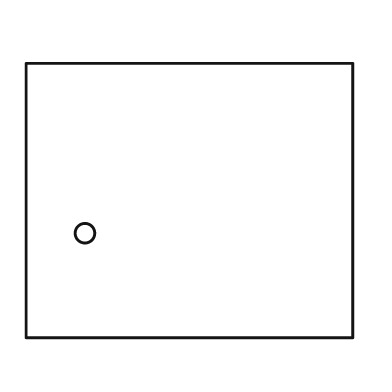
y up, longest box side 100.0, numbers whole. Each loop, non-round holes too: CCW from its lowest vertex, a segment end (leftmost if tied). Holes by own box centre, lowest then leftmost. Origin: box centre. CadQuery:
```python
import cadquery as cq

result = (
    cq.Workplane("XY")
    .moveTo(-50.0, -42.0)
    .lineTo(50.0, -42.0)
    .lineTo(50.0, 42.0)
    .lineTo(-50.0, 42.0)
    .close()
    .moveTo(-32.0, -10.0)
    .circle(3.0)
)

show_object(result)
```